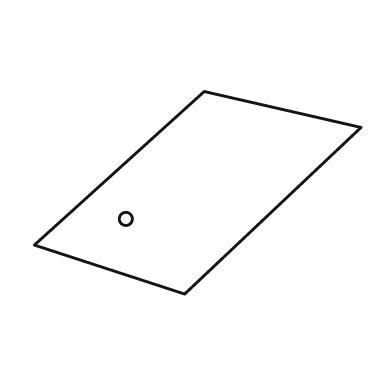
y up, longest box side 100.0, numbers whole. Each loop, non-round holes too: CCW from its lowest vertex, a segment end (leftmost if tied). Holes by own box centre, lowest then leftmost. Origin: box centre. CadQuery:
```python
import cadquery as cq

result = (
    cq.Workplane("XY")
    .moveTo(-4.0, -31.0)
    .lineTo(50.0, 20.0)
    .lineTo(2.0, 31.0)
    .lineTo(-50.0, -16.0)
    .close()
    .moveTo(-22.0, -8.0)
    .circle(2.0)
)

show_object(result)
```